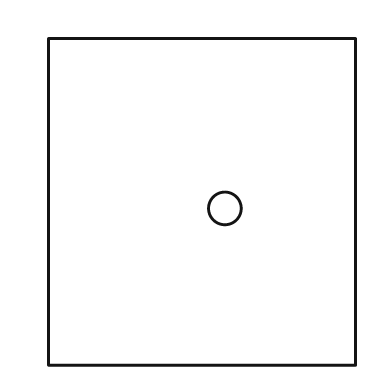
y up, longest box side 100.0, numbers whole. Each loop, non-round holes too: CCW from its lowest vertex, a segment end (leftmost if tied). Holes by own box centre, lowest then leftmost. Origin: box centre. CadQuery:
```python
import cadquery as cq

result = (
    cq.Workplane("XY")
    .moveTo(-47.0, -50.0)
    .lineTo(47.0, -50.0)
    .lineTo(47.0, 50.0)
    .lineTo(-47.0, 50.0)
    .close()
    .moveTo(7.0, -2.0)
    .circle(5.0)
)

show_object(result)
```